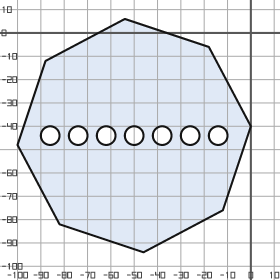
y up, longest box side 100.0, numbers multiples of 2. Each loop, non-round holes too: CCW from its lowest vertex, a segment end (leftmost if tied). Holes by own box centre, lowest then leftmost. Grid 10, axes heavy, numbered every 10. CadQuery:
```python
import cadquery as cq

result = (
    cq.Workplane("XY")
    .moveTo(-46.0, -94.0)
    .lineTo(-12.0, -76.0)
    .lineTo(0.0, -40.0)
    .lineTo(-18.0, -6.0)
    .lineTo(-54.0, 6.0)
    .lineTo(-88.0, -12.0)
    .lineTo(-100.0, -48.0)
    .lineTo(-82.0, -82.0)
    .close()
    .moveTo(-86.0, -44.0)
    .circle(4.0)
    .moveTo(-74.0, -44.0)
    .circle(4.0)
    .moveTo(-62.0, -44.0)
    .circle(4.0)
    .moveTo(-50.0, -44.0)
    .circle(4.0)
    .moveTo(-38.0, -44.0)
    .circle(4.0)
    .moveTo(-26.0, -44.0)
    .circle(4.0)
    .moveTo(-14.0, -44.0)
    .circle(4.0)
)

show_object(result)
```